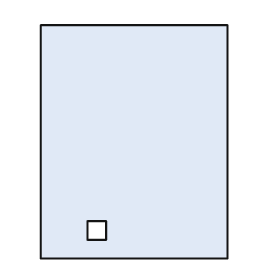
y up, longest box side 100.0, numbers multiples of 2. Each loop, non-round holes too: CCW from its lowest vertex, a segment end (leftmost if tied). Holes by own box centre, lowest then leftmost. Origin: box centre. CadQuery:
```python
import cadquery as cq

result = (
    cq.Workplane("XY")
    .moveTo(-40.0, -50.0)
    .lineTo(40.0, -50.0)
    .lineTo(40.0, 50.0)
    .lineTo(-40.0, 50.0)
    .close()
    .moveTo(-20.0, -42.0)
    .lineTo(-12.0, -42.0)
    .lineTo(-12.0, -34.0)
    .lineTo(-20.0, -34.0)
    .close()
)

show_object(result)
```